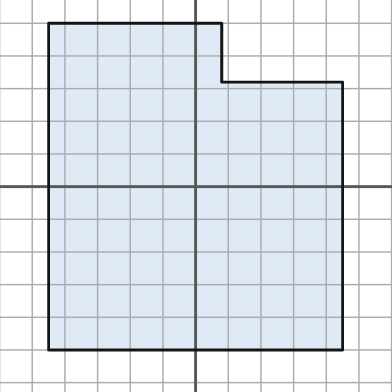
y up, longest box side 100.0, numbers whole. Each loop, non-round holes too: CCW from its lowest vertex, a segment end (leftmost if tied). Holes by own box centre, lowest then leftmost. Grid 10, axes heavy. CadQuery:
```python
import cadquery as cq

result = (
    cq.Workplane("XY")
    .moveTo(-45.0, -50.0)
    .lineTo(45.0, -50.0)
    .lineTo(45.0, 32.0)
    .lineTo(8.0, 32.0)
    .lineTo(8.0, 50.0)
    .lineTo(-45.0, 50.0)
    .close()
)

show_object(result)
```